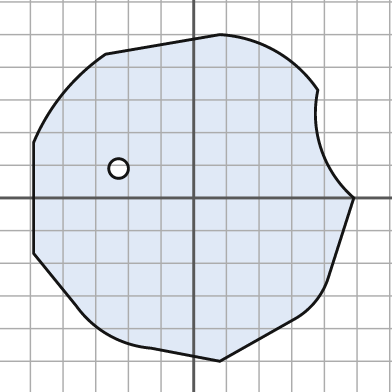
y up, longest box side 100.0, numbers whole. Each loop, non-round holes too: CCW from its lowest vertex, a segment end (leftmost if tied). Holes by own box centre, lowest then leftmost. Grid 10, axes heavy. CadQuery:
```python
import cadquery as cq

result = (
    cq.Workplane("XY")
    .moveTo(8.0, -50.0)
    .lineTo(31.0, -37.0)
    .threePointArc((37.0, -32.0), (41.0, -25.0))
    .lineTo(49.0, 0.0)
    .threePointArc((39.0, 15.0), (38.0, 33.0))
    .threePointArc((25.0, 45.0), (8.0, 50.0))
    .lineTo(-27.0, 44.0)
    .threePointArc((-40.0, 32.0), (-49.0, 17.0))
    .lineTo(-49.0, -17.0)
    .lineTo(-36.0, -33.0)
    .threePointArc((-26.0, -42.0), (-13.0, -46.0))
    .close()
    .moveTo(-23.0, 9.0)
    .circle(3.0)
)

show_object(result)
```